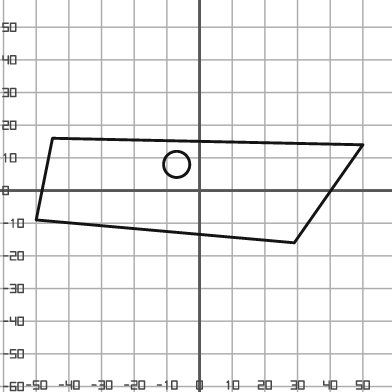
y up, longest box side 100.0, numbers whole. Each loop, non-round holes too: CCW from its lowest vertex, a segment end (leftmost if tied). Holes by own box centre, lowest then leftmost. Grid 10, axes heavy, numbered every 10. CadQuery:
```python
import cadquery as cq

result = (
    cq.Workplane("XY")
    .moveTo(29.0, -16.0)
    .lineTo(50.0, 14.0)
    .lineTo(-45.0, 16.0)
    .lineTo(-50.0, -9.0)
    .close()
    .moveTo(-7.0, 8.0)
    .circle(4.0)
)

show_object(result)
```